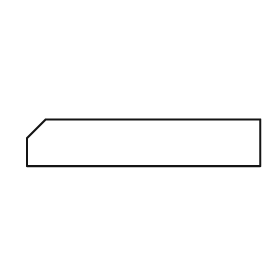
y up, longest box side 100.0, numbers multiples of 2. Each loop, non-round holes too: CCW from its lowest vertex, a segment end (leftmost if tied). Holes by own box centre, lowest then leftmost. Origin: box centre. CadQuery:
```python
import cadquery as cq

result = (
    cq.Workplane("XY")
    .moveTo(-50.0, -10.0)
    .lineTo(50.0, -10.0)
    .lineTo(50.0, 10.0)
    .lineTo(-42.0, 10.0)
    .lineTo(-50.0, 2.0)
    .close()
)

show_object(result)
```